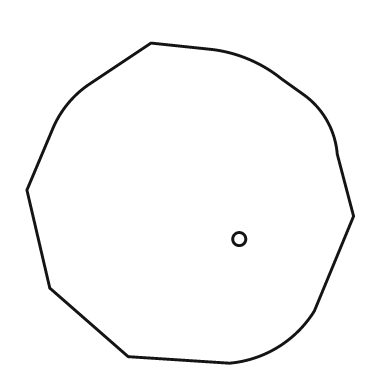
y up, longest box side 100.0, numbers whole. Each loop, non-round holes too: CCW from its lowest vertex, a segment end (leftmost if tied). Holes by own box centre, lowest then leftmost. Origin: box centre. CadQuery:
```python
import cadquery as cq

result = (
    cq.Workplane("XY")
    .moveTo(12.0, -49.0)
    .threePointArc((27.0, -44.0), (38.0, -33.0))
    .lineTo(50.0, -4.0)
    .lineTo(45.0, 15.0)
    .threePointArc((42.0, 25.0), (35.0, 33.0))
    .lineTo(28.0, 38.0)
    .threePointArc((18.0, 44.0), (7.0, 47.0))
    .lineTo(-12.0, 49.0)
    .lineTo(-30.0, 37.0)
    .threePointArc((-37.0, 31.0), (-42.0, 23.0))
    .lineTo(-50.0, 4.0)
    .lineTo(-43.0, -26.0)
    .lineTo(-19.0, -47.0)
    .close()
    .moveTo(15.0, -11.0)
    .circle(2.0)
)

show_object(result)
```